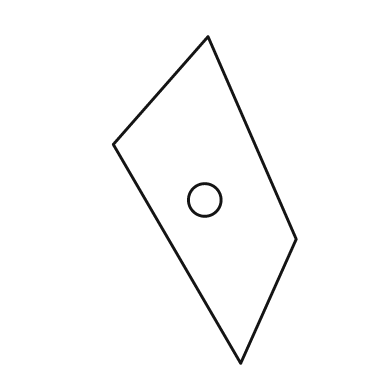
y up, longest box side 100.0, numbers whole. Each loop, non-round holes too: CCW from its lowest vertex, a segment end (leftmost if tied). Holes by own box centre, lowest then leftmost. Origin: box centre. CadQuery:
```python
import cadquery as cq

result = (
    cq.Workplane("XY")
    .moveTo(11.0, -50.0)
    .lineTo(28.0, -12.0)
    .lineTo(1.0, 50.0)
    .lineTo(-28.0, 17.0)
    .close()
    .moveTo(0.0, 0.0)
    .circle(5.0)
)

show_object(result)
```